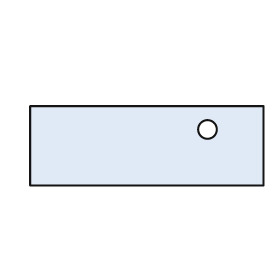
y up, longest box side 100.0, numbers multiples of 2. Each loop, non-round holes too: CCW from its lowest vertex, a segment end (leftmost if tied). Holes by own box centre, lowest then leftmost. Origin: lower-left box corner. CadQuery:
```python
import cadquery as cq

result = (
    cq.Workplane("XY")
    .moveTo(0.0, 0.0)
    .lineTo(100.0, 0.0)
    .lineTo(100.0, 34.0)
    .lineTo(0.0, 34.0)
    .close()
    .moveTo(76.0, 24.0)
    .circle(4.0)
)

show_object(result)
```